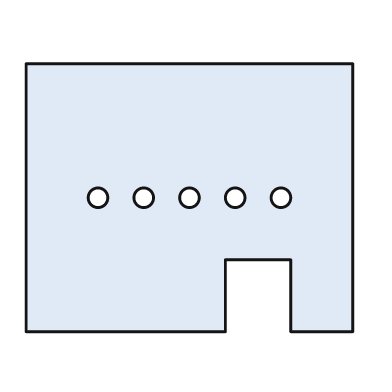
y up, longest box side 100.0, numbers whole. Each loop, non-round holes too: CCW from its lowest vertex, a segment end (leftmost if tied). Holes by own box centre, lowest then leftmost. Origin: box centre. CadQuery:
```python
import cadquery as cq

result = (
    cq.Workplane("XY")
    .moveTo(-50.0, -41.0)
    .lineTo(11.0, -41.0)
    .lineTo(11.0, -19.0)
    .lineTo(31.0, -19.0)
    .lineTo(31.0, -41.0)
    .lineTo(50.0, -41.0)
    .lineTo(50.0, 41.0)
    .lineTo(-50.0, 41.0)
    .close()
    .moveTo(-28.0, 0.0)
    .circle(3.0)
    .moveTo(-14.0, 0.0)
    .circle(3.0)
    .moveTo(0.0, 0.0)
    .circle(3.0)
    .moveTo(14.0, 0.0)
    .circle(3.0)
    .moveTo(28.0, 0.0)
    .circle(3.0)
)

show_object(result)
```